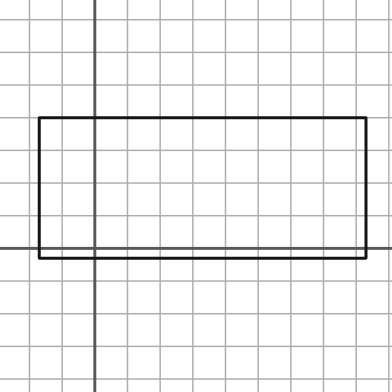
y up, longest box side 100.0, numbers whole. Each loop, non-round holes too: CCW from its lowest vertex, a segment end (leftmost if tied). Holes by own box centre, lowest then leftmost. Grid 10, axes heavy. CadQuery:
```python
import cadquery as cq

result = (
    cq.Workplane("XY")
    .moveTo(-17.0, -3.0)
    .lineTo(83.0, -3.0)
    .lineTo(83.0, 40.0)
    .lineTo(-17.0, 40.0)
    .close()
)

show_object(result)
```